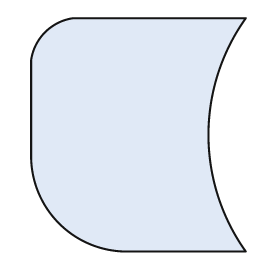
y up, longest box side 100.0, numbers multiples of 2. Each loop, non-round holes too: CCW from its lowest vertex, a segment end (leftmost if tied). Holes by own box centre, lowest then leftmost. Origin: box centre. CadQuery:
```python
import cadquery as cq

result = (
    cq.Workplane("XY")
    .moveTo(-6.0, -50.0)
    .lineTo(46.0, -50.0)
    .threePointArc((30.0, 0.0), (46.0, 50.0))
    .lineTo(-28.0, 50.0)
    .threePointArc((-40.0, 44.0), (-46.0, 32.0))
    .lineTo(-46.0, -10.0)
    .threePointArc((-34.0, -38.0), (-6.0, -50.0))
    .close()
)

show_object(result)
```